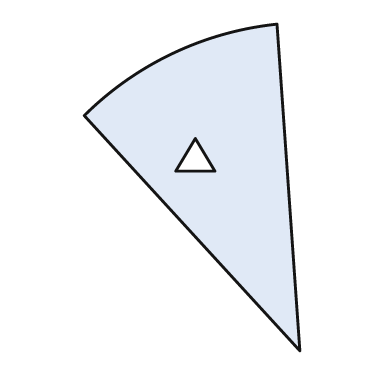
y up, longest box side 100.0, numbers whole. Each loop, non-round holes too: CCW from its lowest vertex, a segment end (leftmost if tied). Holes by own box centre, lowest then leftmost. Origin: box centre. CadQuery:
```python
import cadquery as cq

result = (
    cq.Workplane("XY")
    .moveTo(33.0, -50.0)
    .lineTo(26.0, 50.0)
    .threePointArc((-6.0, 41.0), (-33.0, 22.0))
    .close()
    .moveTo(-5.0, 5.0)
    .lineTo(7.0, 5.0)
    .lineTo(1.0, 15.0)
    .close()
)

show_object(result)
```